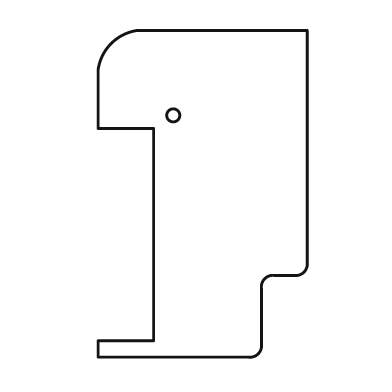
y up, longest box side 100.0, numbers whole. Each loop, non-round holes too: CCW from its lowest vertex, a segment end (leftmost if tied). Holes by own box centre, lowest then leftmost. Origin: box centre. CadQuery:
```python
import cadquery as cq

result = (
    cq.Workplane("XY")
    .moveTo(-32.0, -50.0)
    .lineTo(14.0, -50.0)
    .threePointArc((17.0, -49.0), (18.0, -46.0))
    .lineTo(18.0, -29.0)
    .threePointArc((19.0, -26.0), (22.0, -25.0))
    .lineTo(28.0, -25.0)
    .threePointArc((31.0, -24.0), (32.0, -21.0))
    .lineTo(32.0, 50.0)
    .lineTo(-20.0, 50.0)
    .threePointArc((-28.0, 46.0), (-32.0, 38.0))
    .lineTo(-32.0, 20.0)
    .lineTo(-15.0, 20.0)
    .lineTo(-15.0, -45.0)
    .lineTo(-32.0, -45.0)
    .close()
    .moveTo(-9.0, 24.0)
    .circle(2.0)
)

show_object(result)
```